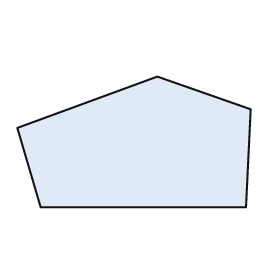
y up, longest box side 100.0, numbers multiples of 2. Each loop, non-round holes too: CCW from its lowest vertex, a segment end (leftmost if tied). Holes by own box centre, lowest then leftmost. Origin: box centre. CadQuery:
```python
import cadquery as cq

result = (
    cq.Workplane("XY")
    .moveTo(-40.0, -28.0)
    .lineTo(48.0, -28.0)
    .lineTo(50.0, 14.0)
    .lineTo(10.0, 28.0)
    .lineTo(-50.0, 6.0)
    .close()
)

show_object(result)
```